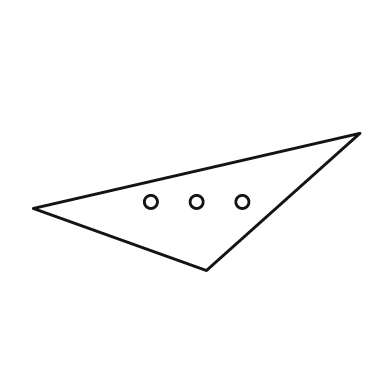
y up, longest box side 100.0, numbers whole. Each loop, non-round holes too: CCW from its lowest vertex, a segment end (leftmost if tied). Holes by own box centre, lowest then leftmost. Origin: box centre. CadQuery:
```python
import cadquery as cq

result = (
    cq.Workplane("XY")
    .moveTo(3.0, -21.0)
    .lineTo(50.0, 21.0)
    .lineTo(-50.0, -2.0)
    .close()
    .moveTo(-14.0, 0.0)
    .circle(2.0)
    .moveTo(0.0, 0.0)
    .circle(2.0)
    .moveTo(14.0, 0.0)
    .circle(2.0)
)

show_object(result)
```